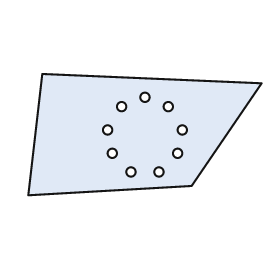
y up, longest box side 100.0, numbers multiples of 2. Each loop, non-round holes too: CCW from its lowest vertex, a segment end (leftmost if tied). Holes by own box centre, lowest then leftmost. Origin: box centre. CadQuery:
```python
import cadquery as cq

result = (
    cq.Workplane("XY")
    .moveTo(-50.0, -26.0)
    .lineTo(20.0, -22.0)
    .lineTo(50.0, 22.0)
    .lineTo(-44.0, 26.0)
    .close()
    .moveTo(-6.0, -16.0)
    .circle(2.0)
    .moveTo(6.0, -16.0)
    .circle(2.0)
    .moveTo(-14.0, -8.0)
    .circle(2.0)
    .moveTo(14.0, -8.0)
    .circle(2.0)
    .moveTo(-16.0, 2.0)
    .circle(2.0)
    .moveTo(16.0, 2.0)
    .circle(2.0)
    .moveTo(-10.0, 12.0)
    .circle(2.0)
    .moveTo(10.0, 12.0)
    .circle(2.0)
    .moveTo(0.0, 16.0)
    .circle(2.0)
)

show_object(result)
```